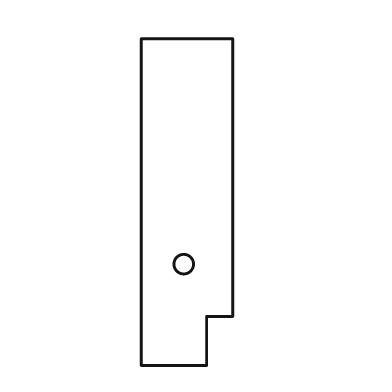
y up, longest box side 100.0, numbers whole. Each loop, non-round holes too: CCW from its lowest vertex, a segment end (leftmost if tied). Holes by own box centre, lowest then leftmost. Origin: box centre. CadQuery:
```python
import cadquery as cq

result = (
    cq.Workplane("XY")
    .moveTo(-14.0, -50.0)
    .lineTo(6.0, -50.0)
    .lineTo(6.0, -35.0)
    .lineTo(14.0, -35.0)
    .lineTo(14.0, 50.0)
    .lineTo(-14.0, 50.0)
    .close()
    .moveTo(-1.0, -19.0)
    .circle(3.0)
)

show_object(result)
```